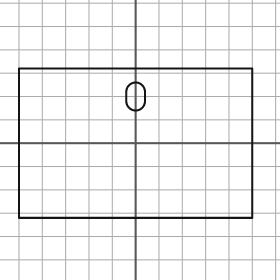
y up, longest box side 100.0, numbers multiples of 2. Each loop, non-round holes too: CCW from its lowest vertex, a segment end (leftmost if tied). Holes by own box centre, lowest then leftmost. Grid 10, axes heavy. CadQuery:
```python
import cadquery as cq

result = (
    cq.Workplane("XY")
    .moveTo(-50.0, -32.0)
    .lineTo(50.0, -32.0)
    .lineTo(50.0, 32.0)
    .lineTo(-50.0, 32.0)
    .close()
    .moveTo(-4.0, 18.0)
    .threePointArc((0.0, 14.0), (4.0, 18.0))
    .lineTo(4.0, 22.0)
    .threePointArc((0.0, 26.0), (-4.0, 22.0))
    .close()
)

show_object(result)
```